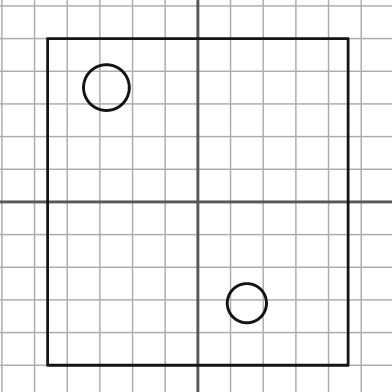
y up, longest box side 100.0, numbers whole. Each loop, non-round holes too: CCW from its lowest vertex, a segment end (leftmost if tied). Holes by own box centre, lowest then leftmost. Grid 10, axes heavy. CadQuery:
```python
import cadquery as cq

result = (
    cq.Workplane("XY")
    .moveTo(-46.0, -50.0)
    .lineTo(46.0, -50.0)
    .lineTo(46.0, 50.0)
    .lineTo(-46.0, 50.0)
    .close()
    .moveTo(15.0, -31.0)
    .circle(6.0)
    .moveTo(-28.0, 35.0)
    .circle(7.0)
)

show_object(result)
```